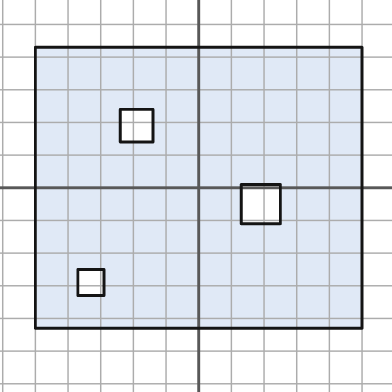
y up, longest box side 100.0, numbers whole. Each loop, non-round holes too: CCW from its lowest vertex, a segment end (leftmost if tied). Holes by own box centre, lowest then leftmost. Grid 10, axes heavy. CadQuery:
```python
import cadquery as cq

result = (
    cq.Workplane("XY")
    .moveTo(-50.0, -43.0)
    .lineTo(50.0, -43.0)
    .lineTo(50.0, 43.0)
    .lineTo(-50.0, 43.0)
    .close()
    .moveTo(-37.0, -33.0)
    .lineTo(-29.0, -33.0)
    .lineTo(-29.0, -25.0)
    .lineTo(-37.0, -25.0)
    .close()
    .moveTo(13.0, -11.0)
    .lineTo(25.0, -11.0)
    .lineTo(25.0, 1.0)
    .lineTo(13.0, 1.0)
    .close()
    .moveTo(-24.0, 14.0)
    .lineTo(-14.0, 14.0)
    .lineTo(-14.0, 24.0)
    .lineTo(-24.0, 24.0)
    .close()
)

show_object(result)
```